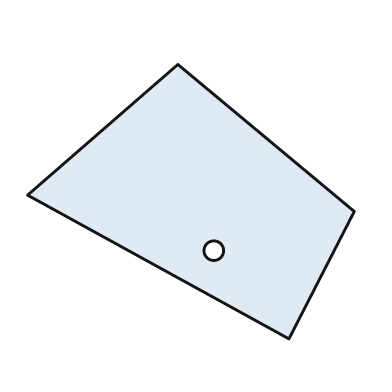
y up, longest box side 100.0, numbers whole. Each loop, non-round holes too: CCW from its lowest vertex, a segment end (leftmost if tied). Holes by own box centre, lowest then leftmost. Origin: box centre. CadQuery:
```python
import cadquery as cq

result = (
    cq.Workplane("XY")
    .moveTo(30.0, -42.0)
    .lineTo(50.0, -3.0)
    .lineTo(-4.0, 42.0)
    .lineTo(-50.0, 2.0)
    .close()
    .moveTo(7.0, -15.0)
    .circle(3.0)
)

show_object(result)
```